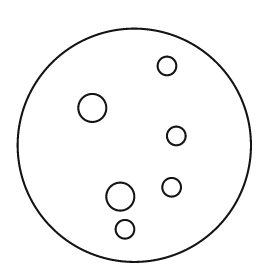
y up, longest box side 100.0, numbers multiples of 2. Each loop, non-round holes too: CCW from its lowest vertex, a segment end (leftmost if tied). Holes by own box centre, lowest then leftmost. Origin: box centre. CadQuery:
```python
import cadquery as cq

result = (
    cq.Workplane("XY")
    .moveTo(0.0, 0.0)
    .circle(50.0)
    .moveTo(-4.0, -36.0)
    .circle(4.0)
    .moveTo(-6.0, -22.0)
    .circle(6.0)
    .moveTo(16.0, -18.0)
    .circle(4.0)
    .moveTo(18.0, 4.0)
    .circle(4.0)
    .moveTo(-18.0, 16.0)
    .circle(6.0)
    .moveTo(14.0, 34.0)
    .circle(4.0)
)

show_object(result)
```